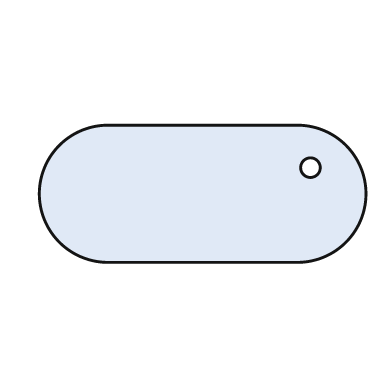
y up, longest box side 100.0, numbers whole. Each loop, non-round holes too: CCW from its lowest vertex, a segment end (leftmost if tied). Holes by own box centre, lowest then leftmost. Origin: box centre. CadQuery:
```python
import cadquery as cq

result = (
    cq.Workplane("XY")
    .moveTo(-29.0, -21.0)
    .lineTo(29.0, -21.0)
    .threePointArc((50.0, 0.0), (29.0, 21.0))
    .lineTo(-29.0, 21.0)
    .threePointArc((-50.0, 0.0), (-29.0, -21.0))
    .close()
    .moveTo(33.0, 8.0)
    .circle(3.0)
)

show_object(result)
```